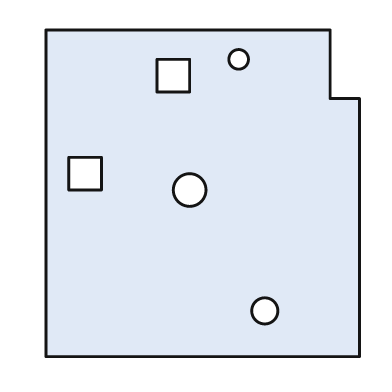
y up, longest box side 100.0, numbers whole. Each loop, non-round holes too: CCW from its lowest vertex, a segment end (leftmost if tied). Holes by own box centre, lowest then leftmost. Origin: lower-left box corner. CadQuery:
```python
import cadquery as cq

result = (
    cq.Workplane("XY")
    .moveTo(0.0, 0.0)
    .lineTo(96.0, 0.0)
    .lineTo(96.0, 79.0)
    .lineTo(87.0, 79.0)
    .lineTo(87.0, 100.0)
    .lineTo(0.0, 100.0)
    .close()
    .moveTo(67.0, 14.0)
    .circle(4.0)
    .moveTo(44.0, 51.0)
    .circle(5.0)
    .moveTo(7.0, 51.0)
    .lineTo(17.0, 51.0)
    .lineTo(17.0, 61.0)
    .lineTo(7.0, 61.0)
    .close()
    .moveTo(34.0, 81.0)
    .lineTo(44.0, 81.0)
    .lineTo(44.0, 91.0)
    .lineTo(34.0, 91.0)
    .close()
    .moveTo(59.0, 91.0)
    .circle(3.0)
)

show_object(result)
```